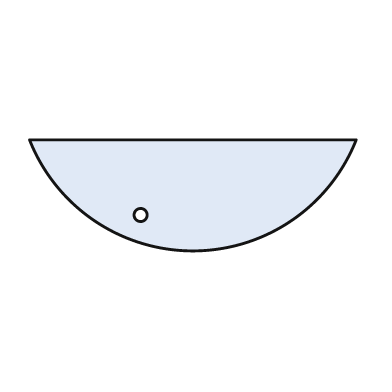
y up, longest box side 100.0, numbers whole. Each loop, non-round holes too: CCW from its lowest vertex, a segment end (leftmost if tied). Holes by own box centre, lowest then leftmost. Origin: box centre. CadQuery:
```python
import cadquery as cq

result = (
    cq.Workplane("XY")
    .moveTo(-50.0, 17.0)
    .threePointArc((0.0, -17.0), (50.0, 17.0))
    .close()
    .moveTo(-16.0, -6.0)
    .circle(2.0)
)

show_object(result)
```